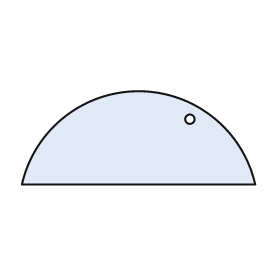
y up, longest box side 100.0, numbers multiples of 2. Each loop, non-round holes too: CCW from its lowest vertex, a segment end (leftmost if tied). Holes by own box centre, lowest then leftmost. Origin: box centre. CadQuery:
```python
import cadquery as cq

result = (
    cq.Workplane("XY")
    .moveTo(-50.0, -20.0)
    .lineTo(50.0, -20.0)
    .threePointArc((0.0, 20.0), (-50.0, -20.0))
    .close()
    .moveTo(22.0, 8.0)
    .circle(2.0)
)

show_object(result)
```